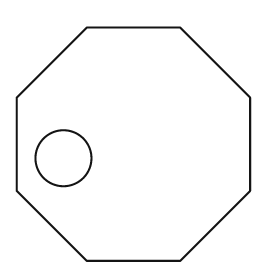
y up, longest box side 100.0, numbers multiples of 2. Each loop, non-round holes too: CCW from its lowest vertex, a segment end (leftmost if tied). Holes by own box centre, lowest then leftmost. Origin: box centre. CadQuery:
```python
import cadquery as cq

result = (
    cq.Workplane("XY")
    .moveTo(-20.0, -50.0)
    .lineTo(20.0, -50.0)
    .lineTo(50.0, -20.0)
    .lineTo(50.0, 20.0)
    .lineTo(20.0, 50.0)
    .lineTo(-20.0, 50.0)
    .lineTo(-50.0, 20.0)
    .lineTo(-50.0, -20.0)
    .close()
    .moveTo(-30.0, -6.0)
    .circle(12.0)
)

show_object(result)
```